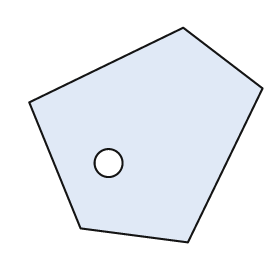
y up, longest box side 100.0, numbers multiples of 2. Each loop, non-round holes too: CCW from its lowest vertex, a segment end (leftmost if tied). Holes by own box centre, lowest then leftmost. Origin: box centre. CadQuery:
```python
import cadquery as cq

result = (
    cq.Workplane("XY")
    .moveTo(18.0, -46.0)
    .lineTo(50.0, 20.0)
    .lineTo(16.0, 46.0)
    .lineTo(-50.0, 14.0)
    .lineTo(-28.0, -40.0)
    .close()
    .moveTo(-16.0, -12.0)
    .circle(6.0)
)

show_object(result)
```